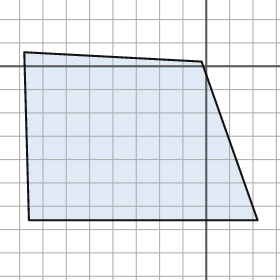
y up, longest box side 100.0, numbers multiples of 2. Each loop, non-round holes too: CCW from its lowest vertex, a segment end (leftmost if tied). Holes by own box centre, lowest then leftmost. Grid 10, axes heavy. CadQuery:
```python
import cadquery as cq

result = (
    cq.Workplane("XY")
    .moveTo(-76.0, -66.0)
    .lineTo(22.0, -66.0)
    .lineTo(-2.0, 2.0)
    .lineTo(-78.0, 6.0)
    .close()
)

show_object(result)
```